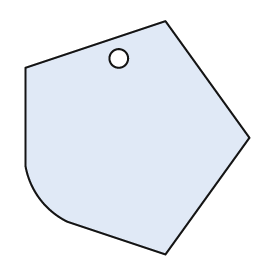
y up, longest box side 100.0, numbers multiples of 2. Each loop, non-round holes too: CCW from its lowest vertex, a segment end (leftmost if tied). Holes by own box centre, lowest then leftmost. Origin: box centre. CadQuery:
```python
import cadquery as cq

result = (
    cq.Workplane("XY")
    .moveTo(12.0, -50.0)
    .lineTo(48.0, 0.0)
    .lineTo(12.0, 50.0)
    .lineTo(-48.0, 30.0)
    .lineTo(-48.0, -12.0)
    .threePointArc((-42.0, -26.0), (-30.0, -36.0))
    .close()
    .moveTo(-8.0, 34.0)
    .circle(4.0)
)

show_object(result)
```